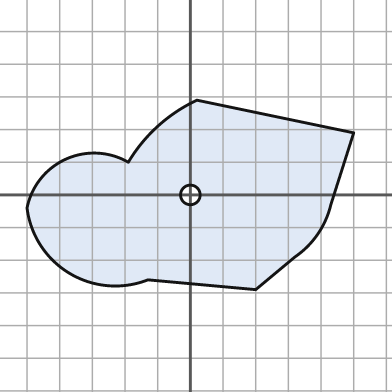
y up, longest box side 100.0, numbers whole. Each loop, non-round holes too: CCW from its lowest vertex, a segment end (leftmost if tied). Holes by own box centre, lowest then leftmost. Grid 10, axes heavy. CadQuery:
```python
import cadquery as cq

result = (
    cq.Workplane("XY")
    .moveTo(20.0, -29.0)
    .lineTo(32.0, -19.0)
    .threePointArc((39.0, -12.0), (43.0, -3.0))
    .lineTo(50.0, 19.0)
    .lineTo(2.0, 29.0)
    .threePointArc((-10.0, 21.0), (-19.0, 10.0))
    .threePointArc((-38.0, 11.0), (-50.0, -4.0))
    .threePointArc((-37.0, -24.0), (-13.0, -26.0))
    .close()
    .moveTo(0.0, 0.0)
    .circle(3.0)
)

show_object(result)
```